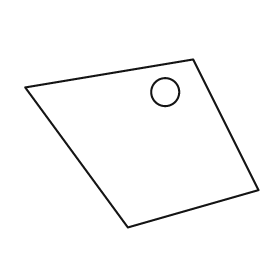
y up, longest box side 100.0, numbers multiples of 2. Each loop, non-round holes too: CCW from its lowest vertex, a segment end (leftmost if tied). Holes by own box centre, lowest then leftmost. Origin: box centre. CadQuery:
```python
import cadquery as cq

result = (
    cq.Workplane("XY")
    .moveTo(-6.0, -36.0)
    .lineTo(50.0, -20.0)
    .lineTo(22.0, 36.0)
    .lineTo(-50.0, 24.0)
    .close()
    .moveTo(10.0, 22.0)
    .circle(6.0)
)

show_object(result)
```